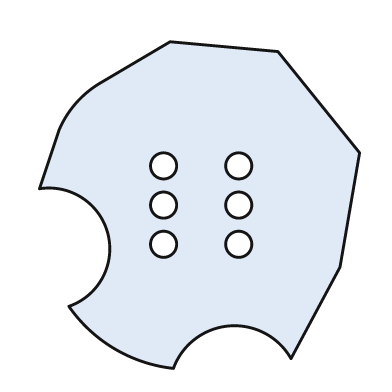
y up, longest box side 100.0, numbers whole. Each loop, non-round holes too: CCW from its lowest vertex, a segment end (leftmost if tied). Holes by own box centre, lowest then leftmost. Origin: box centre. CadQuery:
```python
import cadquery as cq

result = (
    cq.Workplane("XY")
    .moveTo(-8.0, -50.0)
    .threePointArc((9.0, -37.0), (28.0, -47.0))
    .lineTo(43.0, -19.0)
    .lineTo(49.0, 16.0)
    .lineTo(24.0, 47.0)
    .lineTo(-9.0, 50.0)
    .lineTo(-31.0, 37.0)
    .threePointArc((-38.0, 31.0), (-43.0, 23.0))
    .lineTo(-49.0, 5.0)
    .threePointArc((-28.0, -9.0), (-40.0, -31.0))
    .threePointArc((-26.0, -44.0), (-8.0, -50.0))
    .close()
    .moveTo(-11.0, -12.0)
    .circle(4.0)
    .moveTo(12.0, -12.0)
    .circle(4.0)
    .moveTo(-11.0, 0.0)
    .circle(4.0)
    .moveTo(12.0, 0.0)
    .circle(4.0)
    .moveTo(-11.0, 12.0)
    .circle(4.0)
    .moveTo(12.0, 12.0)
    .circle(4.0)
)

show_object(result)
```